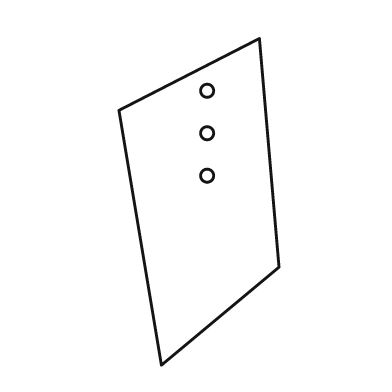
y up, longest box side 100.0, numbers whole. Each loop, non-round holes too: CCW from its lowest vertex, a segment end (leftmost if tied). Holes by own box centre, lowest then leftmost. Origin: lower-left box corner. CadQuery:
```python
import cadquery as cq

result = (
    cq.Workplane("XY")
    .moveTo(13.0, 0.0)
    .lineTo(49.0, 30.0)
    .lineTo(43.0, 100.0)
    .lineTo(0.0, 78.0)
    .close()
    .moveTo(27.0, 58.0)
    .circle(2.0)
    .moveTo(27.0, 71.0)
    .circle(2.0)
    .moveTo(27.0, 84.0)
    .circle(2.0)
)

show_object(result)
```